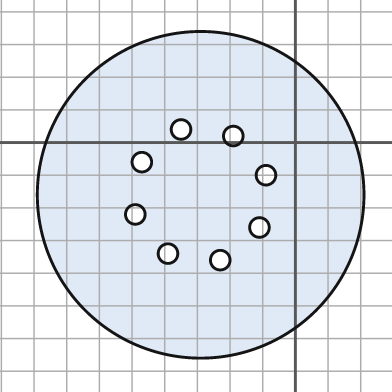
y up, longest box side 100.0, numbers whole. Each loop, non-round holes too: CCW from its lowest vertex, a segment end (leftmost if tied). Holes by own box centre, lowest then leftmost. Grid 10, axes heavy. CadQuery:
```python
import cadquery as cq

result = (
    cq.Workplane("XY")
    .moveTo(-29.0, -16.0)
    .circle(50.0)
    .moveTo(-23.0, -36.0)
    .circle(3.0)
    .moveTo(-39.0, -34.0)
    .circle(3.0)
    .moveTo(-11.0, -26.0)
    .circle(3.0)
    .moveTo(-49.0, -22.0)
    .circle(3.0)
    .moveTo(-9.0, -10.0)
    .circle(3.0)
    .moveTo(-47.0, -6.0)
    .circle(3.0)
    .moveTo(-19.0, 2.0)
    .circle(3.0)
    .moveTo(-35.0, 4.0)
    .circle(3.0)
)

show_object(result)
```